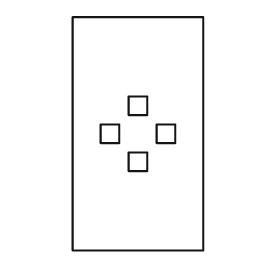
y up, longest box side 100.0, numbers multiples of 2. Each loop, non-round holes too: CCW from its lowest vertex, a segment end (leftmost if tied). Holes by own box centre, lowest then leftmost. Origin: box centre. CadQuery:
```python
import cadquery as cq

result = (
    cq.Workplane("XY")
    .moveTo(-28.0, -50.0)
    .lineTo(28.0, -50.0)
    .lineTo(28.0, 50.0)
    .lineTo(-28.0, 50.0)
    .close()
    .moveTo(-4.0, -16.0)
    .lineTo(4.0, -16.0)
    .lineTo(4.0, -8.0)
    .lineTo(-4.0, -8.0)
    .close()
    .moveTo(-16.0, -4.0)
    .lineTo(-8.0, -4.0)
    .lineTo(-8.0, 4.0)
    .lineTo(-16.0, 4.0)
    .close()
    .moveTo(8.0, -4.0)
    .lineTo(16.0, -4.0)
    .lineTo(16.0, 4.0)
    .lineTo(8.0, 4.0)
    .close()
    .moveTo(-4.0, 8.0)
    .lineTo(4.0, 8.0)
    .lineTo(4.0, 16.0)
    .lineTo(-4.0, 16.0)
    .close()
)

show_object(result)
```